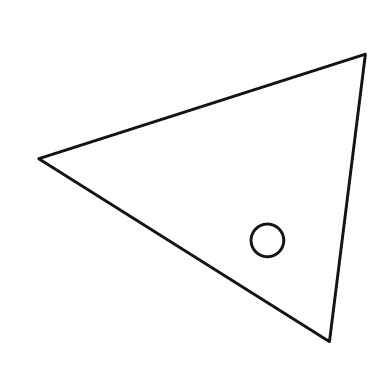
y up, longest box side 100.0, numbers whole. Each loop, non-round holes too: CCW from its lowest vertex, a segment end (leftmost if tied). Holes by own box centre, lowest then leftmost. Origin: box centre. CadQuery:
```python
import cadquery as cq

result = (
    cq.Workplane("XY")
    .moveTo(39.0, -44.0)
    .lineTo(50.0, 44.0)
    .lineTo(-50.0, 12.0)
    .close()
    .moveTo(20.0, -13.0)
    .circle(5.0)
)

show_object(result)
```